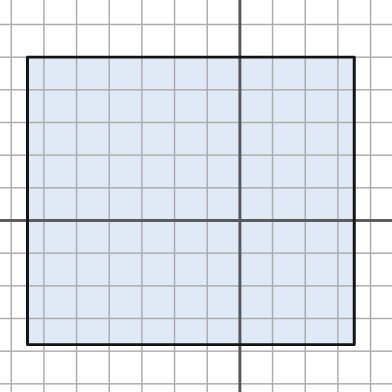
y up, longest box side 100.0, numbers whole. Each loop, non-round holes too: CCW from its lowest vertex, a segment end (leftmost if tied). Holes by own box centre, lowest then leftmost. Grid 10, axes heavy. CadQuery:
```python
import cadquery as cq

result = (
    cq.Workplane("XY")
    .moveTo(-65.0, -38.0)
    .lineTo(35.0, -38.0)
    .lineTo(35.0, 50.0)
    .lineTo(-65.0, 50.0)
    .close()
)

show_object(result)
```